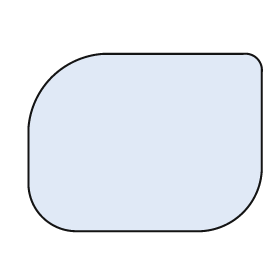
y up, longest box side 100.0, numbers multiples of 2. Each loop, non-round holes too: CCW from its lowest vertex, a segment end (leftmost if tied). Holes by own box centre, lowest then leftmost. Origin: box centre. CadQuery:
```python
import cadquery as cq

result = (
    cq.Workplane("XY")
    .moveTo(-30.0, -38.0)
    .lineTo(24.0, -38.0)
    .threePointArc((42.0, -30.0), (50.0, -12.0))
    .lineTo(50.0, 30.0)
    .threePointArc((48.0, 36.0), (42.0, 38.0))
    .lineTo(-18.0, 38.0)
    .threePointArc((-40.0, 28.0), (-50.0, 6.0))
    .lineTo(-50.0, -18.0)
    .threePointArc((-44.0, -32.0), (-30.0, -38.0))
    .close()
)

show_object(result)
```